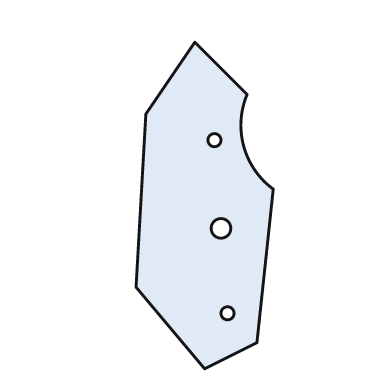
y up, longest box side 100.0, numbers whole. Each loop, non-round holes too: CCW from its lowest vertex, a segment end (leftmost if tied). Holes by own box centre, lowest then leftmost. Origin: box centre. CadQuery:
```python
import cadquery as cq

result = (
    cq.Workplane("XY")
    .moveTo(0.0, -50.0)
    .lineTo(16.0, -42.0)
    .lineTo(21.0, 5.0)
    .threePointArc((12.0, 18.0), (13.0, 34.0))
    .lineTo(-3.0, 50.0)
    .lineTo(-18.0, 28.0)
    .lineTo(-21.0, -25.0)
    .close()
    .moveTo(7.0, -33.0)
    .circle(2.0)
    .moveTo(5.0, -7.0)
    .circle(3.0)
    .moveTo(3.0, 20.0)
    .circle(2.0)
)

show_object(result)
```